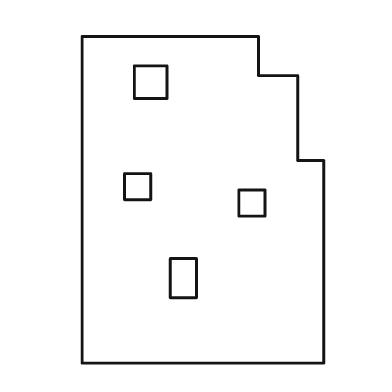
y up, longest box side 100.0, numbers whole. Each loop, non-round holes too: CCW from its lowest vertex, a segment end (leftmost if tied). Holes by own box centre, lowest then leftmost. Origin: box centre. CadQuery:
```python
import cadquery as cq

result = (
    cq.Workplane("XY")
    .moveTo(-37.0, -50.0)
    .lineTo(37.0, -50.0)
    .lineTo(37.0, 12.0)
    .lineTo(29.0, 12.0)
    .lineTo(29.0, 38.0)
    .lineTo(17.0, 38.0)
    .lineTo(17.0, 50.0)
    .lineTo(-37.0, 50.0)
    .close()
    .moveTo(-10.0, -30.0)
    .lineTo(-2.0, -30.0)
    .lineTo(-2.0, -18.0)
    .lineTo(-10.0, -18.0)
    .close()
    .moveTo(11.0, -5.0)
    .lineTo(19.0, -5.0)
    .lineTo(19.0, 3.0)
    .lineTo(11.0, 3.0)
    .close()
    .moveTo(-24.0, 0.0)
    .lineTo(-16.0, 0.0)
    .lineTo(-16.0, 8.0)
    .lineTo(-24.0, 8.0)
    .close()
    .moveTo(-21.0, 31.0)
    .lineTo(-11.0, 31.0)
    .lineTo(-11.0, 41.0)
    .lineTo(-21.0, 41.0)
    .close()
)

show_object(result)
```